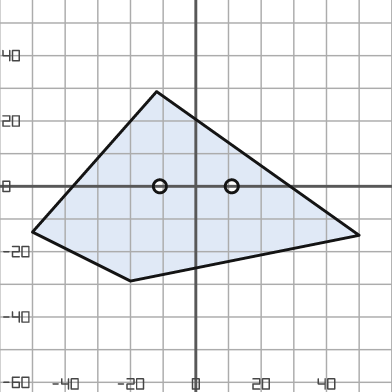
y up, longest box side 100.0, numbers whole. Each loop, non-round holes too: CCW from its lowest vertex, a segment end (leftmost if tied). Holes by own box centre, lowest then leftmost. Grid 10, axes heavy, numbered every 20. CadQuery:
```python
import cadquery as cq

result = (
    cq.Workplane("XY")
    .moveTo(-20.0, -29.0)
    .lineTo(50.0, -15.0)
    .lineTo(-12.0, 29.0)
    .lineTo(-50.0, -14.0)
    .close()
    .moveTo(-11.0, 0.0)
    .circle(2.0)
    .moveTo(11.0, 0.0)
    .circle(2.0)
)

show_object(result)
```